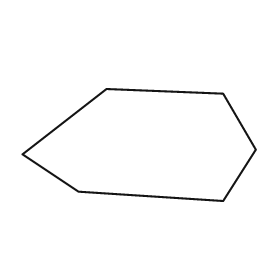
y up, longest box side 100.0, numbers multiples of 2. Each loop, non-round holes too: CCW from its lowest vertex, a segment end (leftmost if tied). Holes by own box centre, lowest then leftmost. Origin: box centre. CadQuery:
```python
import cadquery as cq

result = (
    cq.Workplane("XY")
    .moveTo(36.0, -24.0)
    .lineTo(50.0, -2.0)
    .lineTo(36.0, 22.0)
    .lineTo(-14.0, 24.0)
    .lineTo(-50.0, -4.0)
    .lineTo(-26.0, -20.0)
    .close()
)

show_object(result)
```